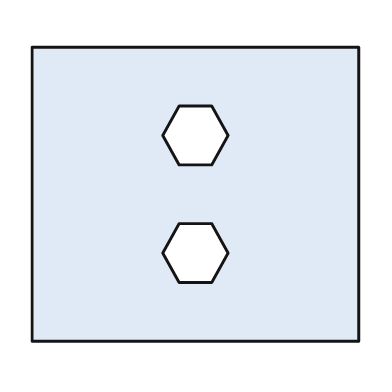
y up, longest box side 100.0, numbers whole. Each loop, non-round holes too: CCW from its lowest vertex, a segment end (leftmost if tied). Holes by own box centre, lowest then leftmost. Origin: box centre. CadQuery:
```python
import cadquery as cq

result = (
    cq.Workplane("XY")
    .moveTo(-50.0, -45.0)
    .lineTo(50.0, -45.0)
    .lineTo(50.0, 45.0)
    .lineTo(-50.0, 45.0)
    .close()
    .moveTo(-5.0, -27.0)
    .lineTo(5.0, -27.0)
    .lineTo(10.0, -18.0)
    .lineTo(5.0, -9.0)
    .lineTo(-5.0, -9.0)
    .lineTo(-10.0, -18.0)
    .close()
    .moveTo(-5.0, 9.0)
    .lineTo(5.0, 9.0)
    .lineTo(10.0, 18.0)
    .lineTo(5.0, 27.0)
    .lineTo(-5.0, 27.0)
    .lineTo(-10.0, 18.0)
    .close()
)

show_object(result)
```